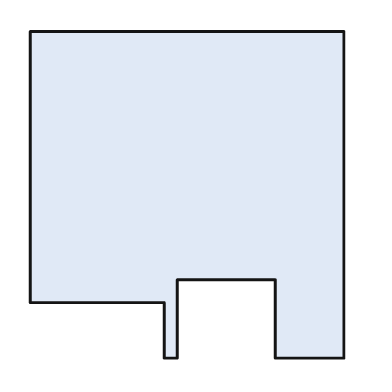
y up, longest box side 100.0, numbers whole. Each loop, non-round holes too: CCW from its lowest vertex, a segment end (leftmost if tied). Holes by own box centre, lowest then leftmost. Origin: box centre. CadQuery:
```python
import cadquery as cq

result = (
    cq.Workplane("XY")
    .moveTo(-7.0, -50.0)
    .lineTo(-3.0, -50.0)
    .lineTo(-3.0, -26.0)
    .lineTo(27.0, -26.0)
    .lineTo(27.0, -50.0)
    .lineTo(48.0, -50.0)
    .lineTo(48.0, 50.0)
    .lineTo(-48.0, 50.0)
    .lineTo(-48.0, -33.0)
    .lineTo(-7.0, -33.0)
    .close()
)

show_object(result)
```